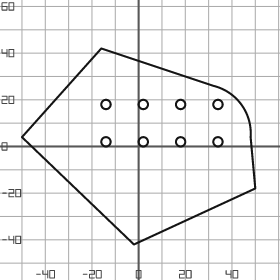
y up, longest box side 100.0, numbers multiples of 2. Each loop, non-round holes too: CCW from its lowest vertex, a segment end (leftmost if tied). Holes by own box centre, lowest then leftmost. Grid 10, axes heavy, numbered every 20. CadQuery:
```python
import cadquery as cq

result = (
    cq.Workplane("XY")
    .moveTo(-2.0, -42.0)
    .lineTo(50.0, -18.0)
    .lineTo(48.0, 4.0)
    .threePointArc((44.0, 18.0), (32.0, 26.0))
    .lineTo(-16.0, 42.0)
    .lineTo(-50.0, 4.0)
    .close()
    .moveTo(-14.0, 2.0)
    .circle(2.0)
    .moveTo(2.0, 2.0)
    .circle(2.0)
    .moveTo(18.0, 2.0)
    .circle(2.0)
    .moveTo(34.0, 2.0)
    .circle(2.0)
    .moveTo(-14.0, 18.0)
    .circle(2.0)
    .moveTo(2.0, 18.0)
    .circle(2.0)
    .moveTo(18.0, 18.0)
    .circle(2.0)
    .moveTo(34.0, 18.0)
    .circle(2.0)
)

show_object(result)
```